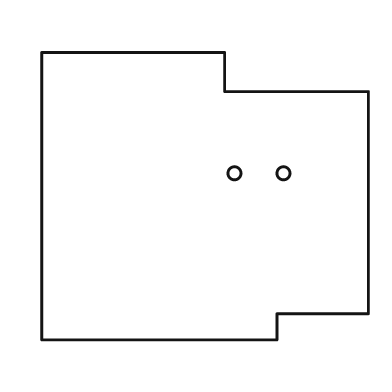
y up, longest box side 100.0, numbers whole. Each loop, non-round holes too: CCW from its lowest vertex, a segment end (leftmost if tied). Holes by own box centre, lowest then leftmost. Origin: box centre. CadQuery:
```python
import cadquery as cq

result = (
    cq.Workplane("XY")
    .moveTo(-50.0, -44.0)
    .lineTo(22.0, -44.0)
    .lineTo(22.0, -36.0)
    .lineTo(50.0, -36.0)
    .lineTo(50.0, 32.0)
    .lineTo(6.0, 32.0)
    .lineTo(6.0, 44.0)
    .lineTo(-50.0, 44.0)
    .close()
    .moveTo(9.0, 7.0)
    .circle(2.0)
    .moveTo(24.0, 7.0)
    .circle(2.0)
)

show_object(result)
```